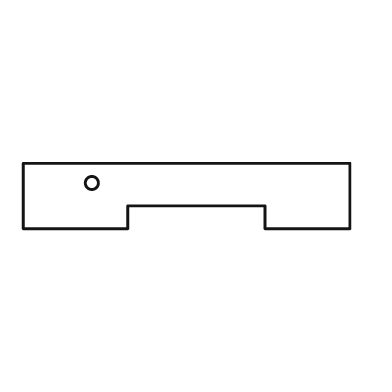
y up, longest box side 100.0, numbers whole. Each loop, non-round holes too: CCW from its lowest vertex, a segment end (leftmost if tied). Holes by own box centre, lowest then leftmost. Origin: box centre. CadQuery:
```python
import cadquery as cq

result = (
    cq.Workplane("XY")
    .moveTo(-50.0, -10.0)
    .lineTo(-18.0, -10.0)
    .lineTo(-18.0, -3.0)
    .lineTo(24.0, -3.0)
    .lineTo(24.0, -10.0)
    .lineTo(50.0, -10.0)
    .lineTo(50.0, 10.0)
    .lineTo(-50.0, 10.0)
    .close()
    .moveTo(-29.0, 4.0)
    .circle(2.0)
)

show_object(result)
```